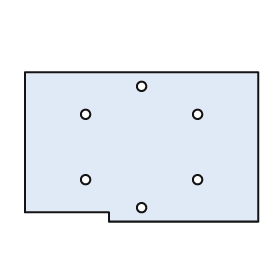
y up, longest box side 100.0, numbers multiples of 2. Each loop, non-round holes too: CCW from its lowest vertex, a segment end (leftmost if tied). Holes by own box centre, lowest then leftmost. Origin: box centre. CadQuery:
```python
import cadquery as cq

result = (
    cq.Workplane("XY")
    .moveTo(-14.0, -32.0)
    .lineTo(50.0, -32.0)
    .lineTo(50.0, 32.0)
    .lineTo(-50.0, 32.0)
    .lineTo(-50.0, -28.0)
    .lineTo(-14.0, -28.0)
    .close()
    .moveTo(0.0, -26.0)
    .circle(2.0)
    .moveTo(-24.0, -14.0)
    .circle(2.0)
    .moveTo(24.0, -14.0)
    .circle(2.0)
    .moveTo(-24.0, 14.0)
    .circle(2.0)
    .moveTo(24.0, 14.0)
    .circle(2.0)
    .moveTo(0.0, 26.0)
    .circle(2.0)
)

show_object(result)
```